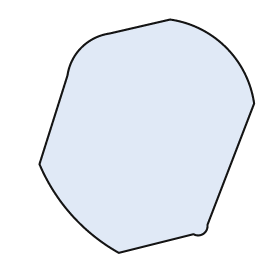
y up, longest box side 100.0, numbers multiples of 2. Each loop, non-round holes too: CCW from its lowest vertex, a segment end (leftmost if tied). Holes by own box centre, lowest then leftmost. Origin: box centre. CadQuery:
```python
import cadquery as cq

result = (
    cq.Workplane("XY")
    .moveTo(-12.0, -50.0)
    .lineTo(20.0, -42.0)
    .threePointArc((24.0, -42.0), (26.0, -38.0))
    .lineTo(46.0, 14.0)
    .threePointArc((34.0, 38.0), (10.0, 50.0))
    .lineTo(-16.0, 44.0)
    .threePointArc((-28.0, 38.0), (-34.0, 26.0))
    .lineTo(-46.0, -12.0)
    .threePointArc((-32.0, -34.0), (-12.0, -50.0))
    .close()
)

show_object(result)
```